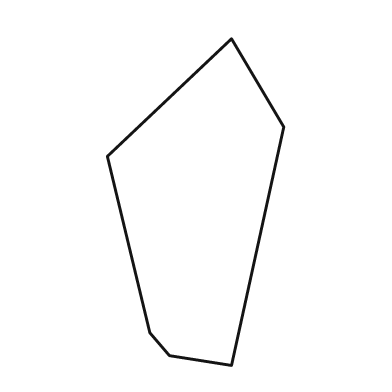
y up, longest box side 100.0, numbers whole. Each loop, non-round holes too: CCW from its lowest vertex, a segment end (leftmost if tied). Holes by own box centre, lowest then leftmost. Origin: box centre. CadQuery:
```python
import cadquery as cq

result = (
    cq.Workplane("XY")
    .moveTo(11.0, -50.0)
    .lineTo(27.0, 23.0)
    .lineTo(11.0, 50.0)
    .lineTo(-27.0, 14.0)
    .lineTo(-14.0, -40.0)
    .lineTo(-8.0, -47.0)
    .close()
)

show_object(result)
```